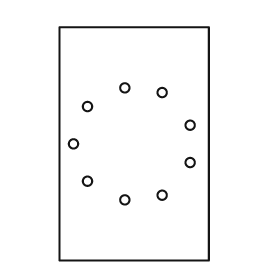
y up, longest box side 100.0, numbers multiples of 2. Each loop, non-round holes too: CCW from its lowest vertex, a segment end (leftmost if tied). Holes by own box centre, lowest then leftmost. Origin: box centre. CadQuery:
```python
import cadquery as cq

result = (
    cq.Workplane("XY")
    .moveTo(-32.0, -50.0)
    .lineTo(32.0, -50.0)
    .lineTo(32.0, 50.0)
    .lineTo(-32.0, 50.0)
    .close()
    .moveTo(-4.0, -24.0)
    .circle(2.0)
    .moveTo(12.0, -22.0)
    .circle(2.0)
    .moveTo(-20.0, -16.0)
    .circle(2.0)
    .moveTo(24.0, -8.0)
    .circle(2.0)
    .moveTo(-26.0, 0.0)
    .circle(2.0)
    .moveTo(24.0, 8.0)
    .circle(2.0)
    .moveTo(-20.0, 16.0)
    .circle(2.0)
    .moveTo(12.0, 22.0)
    .circle(2.0)
    .moveTo(-4.0, 24.0)
    .circle(2.0)
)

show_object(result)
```